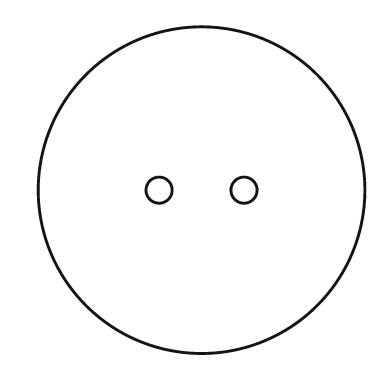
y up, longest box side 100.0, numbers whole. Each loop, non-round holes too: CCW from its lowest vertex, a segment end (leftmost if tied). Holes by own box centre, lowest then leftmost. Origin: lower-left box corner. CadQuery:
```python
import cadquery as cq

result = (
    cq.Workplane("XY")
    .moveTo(50.0, 50.0)
    .circle(50.0)
    .moveTo(37.0, 50.0)
    .circle(4.0)
    .moveTo(63.0, 50.0)
    .circle(4.0)
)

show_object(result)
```